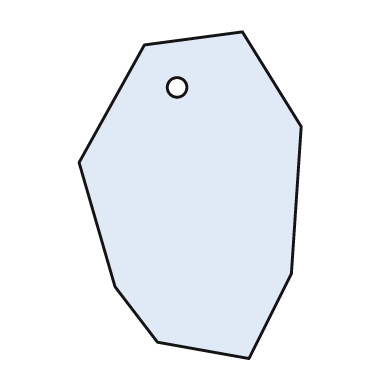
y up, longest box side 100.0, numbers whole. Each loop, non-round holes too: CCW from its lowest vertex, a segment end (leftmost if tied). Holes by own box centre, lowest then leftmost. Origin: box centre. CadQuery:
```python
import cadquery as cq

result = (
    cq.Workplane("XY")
    .moveTo(18.0, -50.0)
    .lineTo(31.0, -24.0)
    .lineTo(34.0, 21.0)
    .lineTo(16.0, 50.0)
    .lineTo(-14.0, 46.0)
    .lineTo(-34.0, 10.0)
    .lineTo(-23.0, -28.0)
    .lineTo(-10.0, -45.0)
    .close()
    .moveTo(-4.0, 33.0)
    .circle(3.0)
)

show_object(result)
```